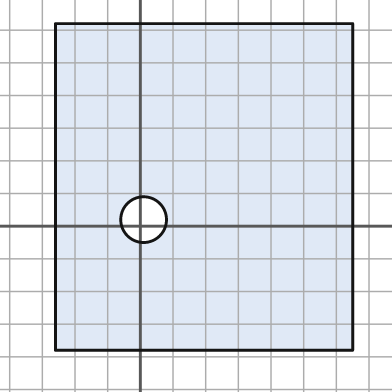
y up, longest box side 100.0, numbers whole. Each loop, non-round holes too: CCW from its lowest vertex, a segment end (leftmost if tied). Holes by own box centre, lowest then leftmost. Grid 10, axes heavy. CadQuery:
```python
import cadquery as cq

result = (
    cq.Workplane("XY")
    .moveTo(-26.0, -38.0)
    .lineTo(65.0, -38.0)
    .lineTo(65.0, 62.0)
    .lineTo(-26.0, 62.0)
    .close()
    .moveTo(1.0, 2.0)
    .circle(7.0)
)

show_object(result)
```